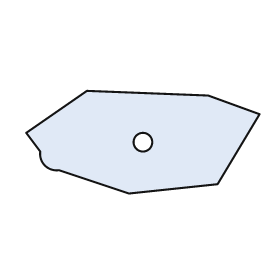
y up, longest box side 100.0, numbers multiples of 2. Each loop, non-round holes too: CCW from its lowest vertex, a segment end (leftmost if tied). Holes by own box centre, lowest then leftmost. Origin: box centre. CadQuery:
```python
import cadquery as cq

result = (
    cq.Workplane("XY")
    .moveTo(-6.0, -22.0)
    .lineTo(32.0, -18.0)
    .lineTo(50.0, 12.0)
    .lineTo(28.0, 20.0)
    .lineTo(-24.0, 22.0)
    .lineTo(-50.0, 4.0)
    .lineTo(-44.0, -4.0)
    .threePointArc((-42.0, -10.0), (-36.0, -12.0))
    .close()
    .moveTo(0.0, 0.0)
    .circle(4.0)
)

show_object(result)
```